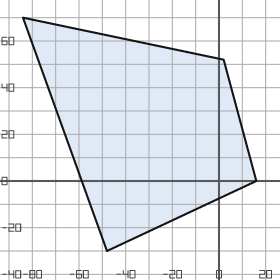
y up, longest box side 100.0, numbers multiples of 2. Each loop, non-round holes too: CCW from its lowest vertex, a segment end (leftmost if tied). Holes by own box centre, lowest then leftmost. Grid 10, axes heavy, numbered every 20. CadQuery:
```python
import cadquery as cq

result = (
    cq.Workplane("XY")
    .moveTo(-48.0, -30.0)
    .lineTo(16.0, 0.0)
    .lineTo(2.0, 52.0)
    .lineTo(-84.0, 70.0)
    .close()
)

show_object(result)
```